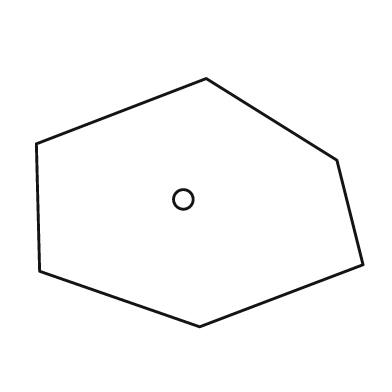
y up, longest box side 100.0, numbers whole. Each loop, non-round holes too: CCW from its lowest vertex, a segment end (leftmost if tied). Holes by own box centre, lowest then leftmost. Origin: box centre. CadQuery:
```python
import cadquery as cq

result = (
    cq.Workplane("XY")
    .moveTo(0.0, -38.0)
    .lineTo(50.0, -19.0)
    .lineTo(42.0, 13.0)
    .lineTo(2.0, 38.0)
    .lineTo(-50.0, 18.0)
    .lineTo(-49.0, -21.0)
    .close()
    .moveTo(-5.0, 1.0)
    .circle(3.0)
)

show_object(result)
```